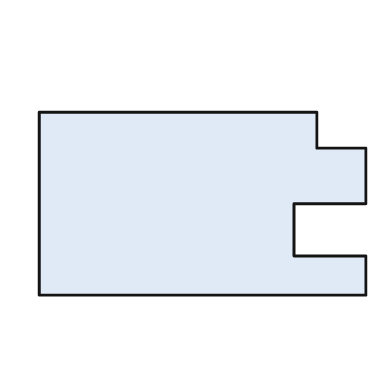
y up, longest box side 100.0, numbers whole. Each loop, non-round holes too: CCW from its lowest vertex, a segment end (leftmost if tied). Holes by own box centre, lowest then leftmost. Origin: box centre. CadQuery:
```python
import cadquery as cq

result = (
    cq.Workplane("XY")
    .moveTo(-50.0, -28.0)
    .lineTo(50.0, -28.0)
    .lineTo(50.0, -16.0)
    .lineTo(28.0, -16.0)
    .lineTo(28.0, 0.0)
    .lineTo(50.0, 0.0)
    .lineTo(50.0, 17.0)
    .lineTo(35.0, 17.0)
    .lineTo(35.0, 28.0)
    .lineTo(-50.0, 28.0)
    .close()
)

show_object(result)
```